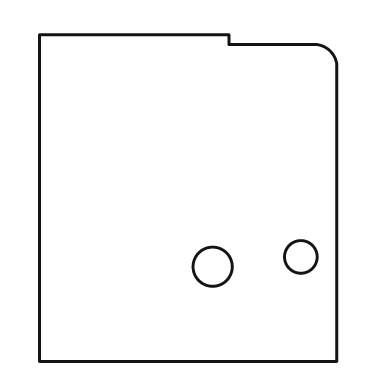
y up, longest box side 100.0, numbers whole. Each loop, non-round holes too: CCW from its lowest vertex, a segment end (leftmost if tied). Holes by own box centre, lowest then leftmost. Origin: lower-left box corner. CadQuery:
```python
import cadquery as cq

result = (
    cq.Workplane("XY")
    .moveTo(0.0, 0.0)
    .lineTo(91.0, 0.0)
    .lineTo(91.0, 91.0)
    .threePointArc((89.0, 95.0), (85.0, 97.0))
    .lineTo(58.0, 97.0)
    .lineTo(58.0, 100.0)
    .lineTo(0.0, 100.0)
    .close()
    .moveTo(53.0, 29.0)
    .circle(6.0)
    .moveTo(80.0, 32.0)
    .circle(5.0)
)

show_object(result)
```